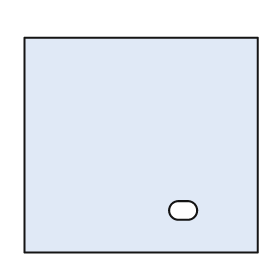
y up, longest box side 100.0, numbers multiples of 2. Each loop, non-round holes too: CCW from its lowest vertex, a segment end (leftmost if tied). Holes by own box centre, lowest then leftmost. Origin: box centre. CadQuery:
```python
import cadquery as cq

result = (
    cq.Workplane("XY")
    .moveTo(-50.0, -46.0)
    .lineTo(50.0, -46.0)
    .lineTo(50.0, 46.0)
    .lineTo(-50.0, 46.0)
    .close()
    .moveTo(16.0, -32.0)
    .lineTo(20.0, -32.0)
    .threePointArc((24.0, -28.0), (20.0, -24.0))
    .lineTo(16.0, -24.0)
    .threePointArc((12.0, -28.0), (16.0, -32.0))
    .close()
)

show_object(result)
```